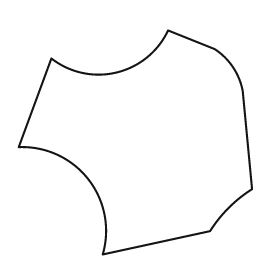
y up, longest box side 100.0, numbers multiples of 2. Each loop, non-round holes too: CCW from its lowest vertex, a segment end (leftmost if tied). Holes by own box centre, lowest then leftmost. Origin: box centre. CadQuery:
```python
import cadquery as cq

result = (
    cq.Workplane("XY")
    .moveTo(-14.0, -48.0)
    .lineTo(32.0, -38.0)
    .threePointArc((40.0, -28.0), (50.0, -20.0))
    .lineTo(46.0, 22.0)
    .threePointArc((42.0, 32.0), (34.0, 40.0))
    .lineTo(14.0, 48.0)
    .threePointArc((-8.0, 30.0), (-36.0, 36.0))
    .lineTo(-50.0, -2.0)
    .threePointArc((-20.0, -16.0), (-14.0, -48.0))
    .close()
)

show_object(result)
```